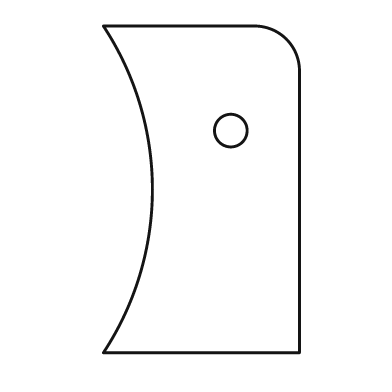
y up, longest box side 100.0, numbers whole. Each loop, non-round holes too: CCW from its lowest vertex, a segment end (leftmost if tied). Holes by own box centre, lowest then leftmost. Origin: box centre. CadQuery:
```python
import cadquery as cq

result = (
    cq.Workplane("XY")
    .moveTo(-30.0, -50.0)
    .lineTo(30.0, -50.0)
    .lineTo(30.0, 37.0)
    .threePointArc((26.0, 46.0), (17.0, 50.0))
    .lineTo(-30.0, 50.0)
    .threePointArc((-15.0, 0.0), (-30.0, -50.0))
    .close()
    .moveTo(9.0, 18.0)
    .circle(5.0)
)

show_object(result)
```